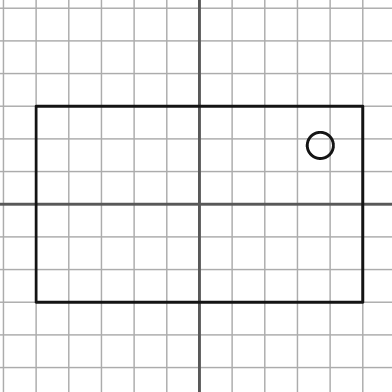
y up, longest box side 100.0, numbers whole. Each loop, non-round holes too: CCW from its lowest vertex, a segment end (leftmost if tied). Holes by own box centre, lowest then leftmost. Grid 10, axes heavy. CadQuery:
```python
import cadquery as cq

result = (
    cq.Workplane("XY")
    .moveTo(-50.0, -30.0)
    .lineTo(50.0, -30.0)
    .lineTo(50.0, 30.0)
    .lineTo(-50.0, 30.0)
    .close()
    .moveTo(37.0, 18.0)
    .circle(4.0)
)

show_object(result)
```